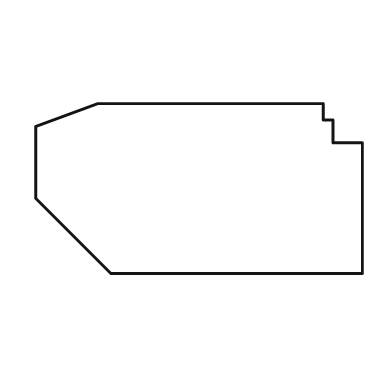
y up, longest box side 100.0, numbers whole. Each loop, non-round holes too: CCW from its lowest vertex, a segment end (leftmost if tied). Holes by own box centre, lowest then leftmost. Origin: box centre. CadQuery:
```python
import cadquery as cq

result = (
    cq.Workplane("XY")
    .moveTo(-27.0, -26.0)
    .lineTo(50.0, -26.0)
    .lineTo(50.0, 14.0)
    .lineTo(41.0, 14.0)
    .lineTo(41.0, 21.0)
    .lineTo(38.0, 21.0)
    .lineTo(38.0, 26.0)
    .lineTo(-31.0, 26.0)
    .lineTo(-50.0, 19.0)
    .lineTo(-50.0, -3.0)
    .close()
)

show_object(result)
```